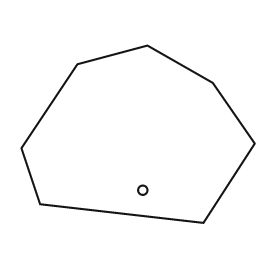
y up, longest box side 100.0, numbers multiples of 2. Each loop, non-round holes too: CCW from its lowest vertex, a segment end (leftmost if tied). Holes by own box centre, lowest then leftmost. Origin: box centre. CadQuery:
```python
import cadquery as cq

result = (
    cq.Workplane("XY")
    .moveTo(28.0, -38.0)
    .lineTo(50.0, -4.0)
    .lineTo(32.0, 22.0)
    .lineTo(4.0, 38.0)
    .lineTo(-26.0, 30.0)
    .lineTo(-50.0, -6.0)
    .lineTo(-42.0, -30.0)
    .close()
    .moveTo(2.0, -24.0)
    .circle(2.0)
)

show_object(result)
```